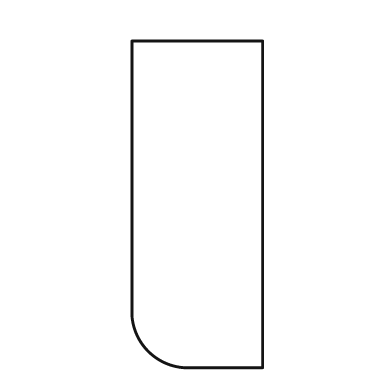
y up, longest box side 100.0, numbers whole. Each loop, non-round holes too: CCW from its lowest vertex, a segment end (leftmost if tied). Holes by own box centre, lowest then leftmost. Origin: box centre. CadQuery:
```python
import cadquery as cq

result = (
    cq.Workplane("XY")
    .moveTo(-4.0, -50.0)
    .lineTo(20.0, -50.0)
    .lineTo(20.0, 50.0)
    .lineTo(-20.0, 50.0)
    .lineTo(-20.0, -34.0)
    .threePointArc((-15.0, -45.0), (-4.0, -50.0))
    .close()
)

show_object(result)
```